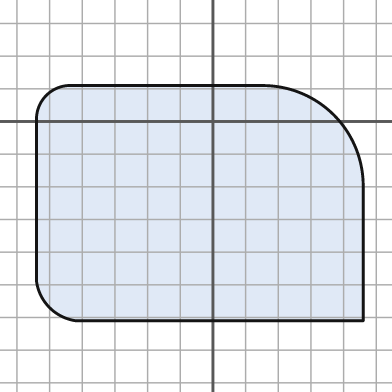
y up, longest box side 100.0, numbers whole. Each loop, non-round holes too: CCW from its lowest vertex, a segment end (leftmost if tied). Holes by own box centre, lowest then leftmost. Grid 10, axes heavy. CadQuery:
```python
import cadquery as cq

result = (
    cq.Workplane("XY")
    .moveTo(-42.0, -61.0)
    .lineTo(46.0, -61.0)
    .lineTo(46.0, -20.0)
    .threePointArc((37.0, 2.0), (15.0, 11.0))
    .lineTo(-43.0, 11.0)
    .threePointArc((-51.0, 8.0), (-54.0, 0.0))
    .lineTo(-54.0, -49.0)
    .threePointArc((-50.0, -57.0), (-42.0, -61.0))
    .close()
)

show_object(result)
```